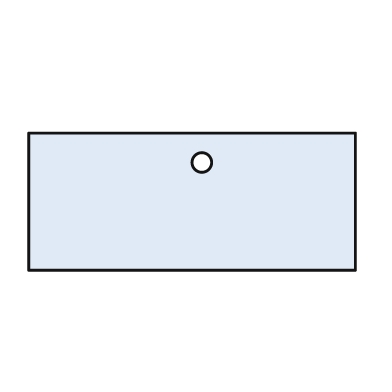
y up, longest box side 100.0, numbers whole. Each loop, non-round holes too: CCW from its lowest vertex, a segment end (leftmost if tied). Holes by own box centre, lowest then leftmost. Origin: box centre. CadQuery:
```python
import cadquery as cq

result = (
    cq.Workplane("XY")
    .moveTo(-50.0, -21.0)
    .lineTo(50.0, -21.0)
    .lineTo(50.0, 21.0)
    .lineTo(-50.0, 21.0)
    .close()
    .moveTo(3.0, 12.0)
    .circle(3.0)
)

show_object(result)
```